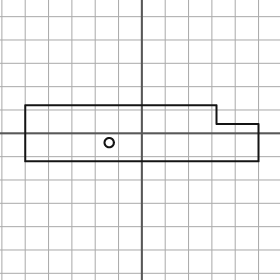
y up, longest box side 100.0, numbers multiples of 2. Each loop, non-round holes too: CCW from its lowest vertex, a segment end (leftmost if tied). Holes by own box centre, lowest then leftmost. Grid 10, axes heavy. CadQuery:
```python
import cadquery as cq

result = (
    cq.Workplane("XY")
    .moveTo(-50.0, -12.0)
    .lineTo(50.0, -12.0)
    .lineTo(50.0, 4.0)
    .lineTo(32.0, 4.0)
    .lineTo(32.0, 12.0)
    .lineTo(-50.0, 12.0)
    .close()
    .moveTo(-14.0, -4.0)
    .circle(2.0)
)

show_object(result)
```